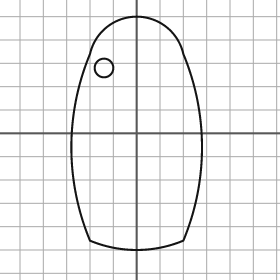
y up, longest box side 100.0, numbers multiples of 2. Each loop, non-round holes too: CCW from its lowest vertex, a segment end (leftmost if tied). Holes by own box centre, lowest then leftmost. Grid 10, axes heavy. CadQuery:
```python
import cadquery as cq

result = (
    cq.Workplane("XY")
    .moveTo(-20.0, -46.0)
    .threePointArc((0.0, -50.0), (20.0, -46.0))
    .threePointArc((28.0, -6.0), (20.0, 34.0))
    .threePointArc((0.0, 50.0), (-20.0, 34.0))
    .threePointArc((-28.0, -6.0), (-20.0, -46.0))
    .close()
    .moveTo(-14.0, 28.0)
    .circle(4.0)
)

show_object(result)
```